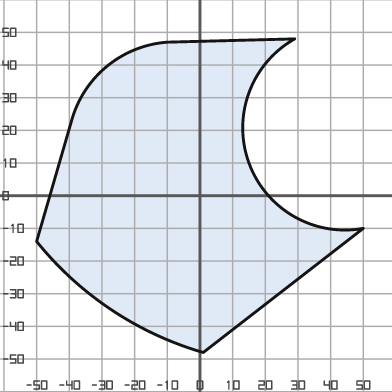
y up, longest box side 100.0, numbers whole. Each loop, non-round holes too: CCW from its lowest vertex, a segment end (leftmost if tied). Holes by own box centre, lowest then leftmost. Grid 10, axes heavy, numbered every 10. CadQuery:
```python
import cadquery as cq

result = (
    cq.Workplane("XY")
    .moveTo(1.0, -48.0)
    .lineTo(50.0, -10.0)
    .threePointArc((15.0, 10.0), (29.0, 48.0))
    .lineTo(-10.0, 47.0)
    .threePointArc((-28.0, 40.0), (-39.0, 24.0))
    .lineTo(-50.0, -14.0)
    .threePointArc((-27.0, -35.0), (1.0, -48.0))
    .close()
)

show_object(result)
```